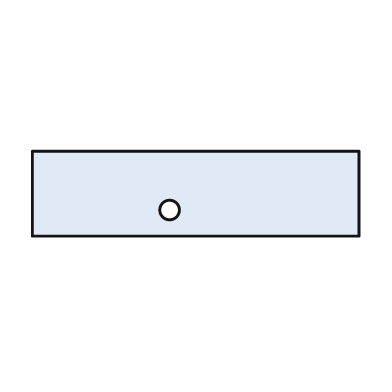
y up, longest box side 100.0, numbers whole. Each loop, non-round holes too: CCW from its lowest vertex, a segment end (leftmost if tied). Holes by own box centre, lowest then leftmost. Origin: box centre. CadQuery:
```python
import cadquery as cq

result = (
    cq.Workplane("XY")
    .moveTo(-50.0, -13.0)
    .lineTo(50.0, -13.0)
    .lineTo(50.0, 13.0)
    .lineTo(-50.0, 13.0)
    .close()
    .moveTo(-8.0, -5.0)
    .circle(3.0)
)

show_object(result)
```